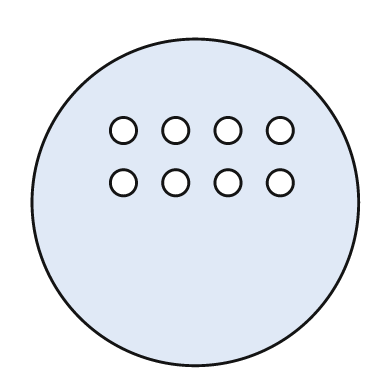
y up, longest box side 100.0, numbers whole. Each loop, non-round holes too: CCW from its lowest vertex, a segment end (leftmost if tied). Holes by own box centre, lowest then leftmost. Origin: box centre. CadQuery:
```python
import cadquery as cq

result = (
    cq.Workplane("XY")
    .moveTo(0.0, 0.0)
    .circle(50.0)
    .moveTo(-22.0, 6.0)
    .circle(4.0)
    .moveTo(-6.0, 6.0)
    .circle(4.0)
    .moveTo(10.0, 6.0)
    .circle(4.0)
    .moveTo(26.0, 6.0)
    .circle(4.0)
    .moveTo(-22.0, 22.0)
    .circle(4.0)
    .moveTo(-6.0, 22.0)
    .circle(4.0)
    .moveTo(10.0, 22.0)
    .circle(4.0)
    .moveTo(26.0, 22.0)
    .circle(4.0)
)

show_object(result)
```